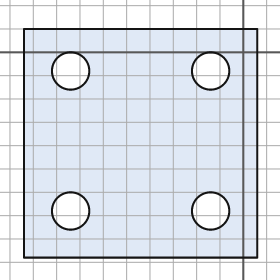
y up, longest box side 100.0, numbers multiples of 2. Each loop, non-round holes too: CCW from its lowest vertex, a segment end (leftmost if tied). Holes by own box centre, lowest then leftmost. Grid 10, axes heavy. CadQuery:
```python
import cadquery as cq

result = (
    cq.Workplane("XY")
    .moveTo(-94.0, -88.0)
    .lineTo(6.0, -88.0)
    .lineTo(6.0, 10.0)
    .lineTo(-94.0, 10.0)
    .close()
    .moveTo(-74.0, -68.0)
    .circle(8.0)
    .moveTo(-14.0, -68.0)
    .circle(8.0)
    .moveTo(-74.0, -8.0)
    .circle(8.0)
    .moveTo(-14.0, -8.0)
    .circle(8.0)
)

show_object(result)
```